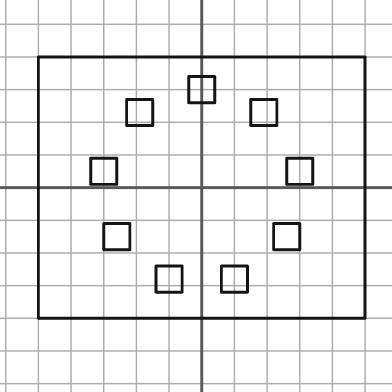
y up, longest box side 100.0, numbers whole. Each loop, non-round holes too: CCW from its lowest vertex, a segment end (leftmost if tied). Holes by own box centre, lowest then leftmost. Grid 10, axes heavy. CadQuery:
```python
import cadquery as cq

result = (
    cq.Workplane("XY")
    .moveTo(-50.0, -40.0)
    .lineTo(50.0, -40.0)
    .lineTo(50.0, 40.0)
    .lineTo(-50.0, 40.0)
    .close()
    .moveTo(-14.0, -32.0)
    .lineTo(-6.0, -32.0)
    .lineTo(-6.0, -24.0)
    .lineTo(-14.0, -24.0)
    .close()
    .moveTo(6.0, -32.0)
    .lineTo(14.0, -32.0)
    .lineTo(14.0, -24.0)
    .lineTo(6.0, -24.0)
    .close()
    .moveTo(-30.0, -19.0)
    .lineTo(-22.0, -19.0)
    .lineTo(-22.0, -11.0)
    .lineTo(-30.0, -11.0)
    .close()
    .moveTo(22.0, -19.0)
    .lineTo(30.0, -19.0)
    .lineTo(30.0, -11.0)
    .lineTo(22.0, -11.0)
    .close()
    .moveTo(-34.0, 1.0)
    .lineTo(-26.0, 1.0)
    .lineTo(-26.0, 9.0)
    .lineTo(-34.0, 9.0)
    .close()
    .moveTo(26.0, 1.0)
    .lineTo(34.0, 1.0)
    .lineTo(34.0, 9.0)
    .lineTo(26.0, 9.0)
    .close()
    .moveTo(-23.0, 19.0)
    .lineTo(-15.0, 19.0)
    .lineTo(-15.0, 27.0)
    .lineTo(-23.0, 27.0)
    .close()
    .moveTo(15.0, 19.0)
    .lineTo(23.0, 19.0)
    .lineTo(23.0, 27.0)
    .lineTo(15.0, 27.0)
    .close()
    .moveTo(-4.0, 26.0)
    .lineTo(4.0, 26.0)
    .lineTo(4.0, 34.0)
    .lineTo(-4.0, 34.0)
    .close()
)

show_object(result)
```